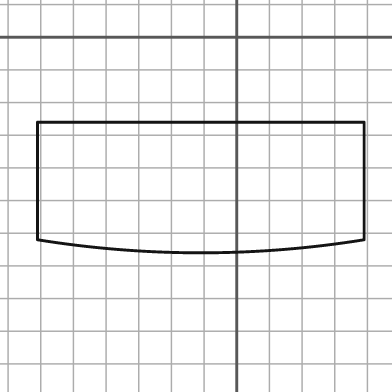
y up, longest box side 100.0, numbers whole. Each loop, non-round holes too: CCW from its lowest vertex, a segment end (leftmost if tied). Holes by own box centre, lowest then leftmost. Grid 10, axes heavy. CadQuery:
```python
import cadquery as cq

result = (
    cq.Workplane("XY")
    .moveTo(-61.0, -62.0)
    .threePointArc((-11.0, -66.0), (39.0, -62.0))
    .lineTo(39.0, -26.0)
    .lineTo(-61.0, -26.0)
    .close()
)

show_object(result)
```